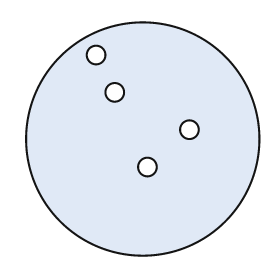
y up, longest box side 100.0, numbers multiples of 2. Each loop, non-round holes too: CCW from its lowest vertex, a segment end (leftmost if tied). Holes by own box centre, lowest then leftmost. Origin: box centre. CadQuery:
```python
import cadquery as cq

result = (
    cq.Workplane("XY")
    .moveTo(0.0, 0.0)
    .circle(50.0)
    .moveTo(2.0, -12.0)
    .circle(4.0)
    .moveTo(20.0, 4.0)
    .circle(4.0)
    .moveTo(-12.0, 20.0)
    .circle(4.0)
    .moveTo(-20.0, 36.0)
    .circle(4.0)
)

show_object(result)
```